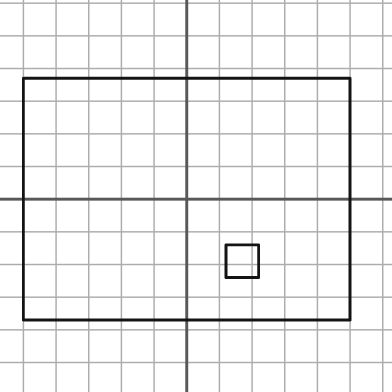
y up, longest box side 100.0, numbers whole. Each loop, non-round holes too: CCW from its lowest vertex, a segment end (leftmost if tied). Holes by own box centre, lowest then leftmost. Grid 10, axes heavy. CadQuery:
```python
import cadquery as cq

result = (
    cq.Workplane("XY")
    .moveTo(-50.0, -37.0)
    .lineTo(50.0, -37.0)
    .lineTo(50.0, 37.0)
    .lineTo(-50.0, 37.0)
    .close()
    .moveTo(12.0, -24.0)
    .lineTo(22.0, -24.0)
    .lineTo(22.0, -14.0)
    .lineTo(12.0, -14.0)
    .close()
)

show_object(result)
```